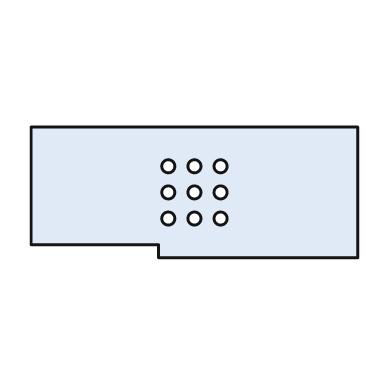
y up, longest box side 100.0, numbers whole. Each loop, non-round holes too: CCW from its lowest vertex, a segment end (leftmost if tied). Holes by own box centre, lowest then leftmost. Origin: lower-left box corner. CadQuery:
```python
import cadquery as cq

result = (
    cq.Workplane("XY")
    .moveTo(39.0, 0.0)
    .lineTo(100.0, 0.0)
    .lineTo(100.0, 40.0)
    .lineTo(0.0, 40.0)
    .lineTo(0.0, 4.0)
    .lineTo(39.0, 4.0)
    .close()
    .moveTo(42.0, 12.0)
    .circle(2.0)
    .moveTo(50.0, 12.0)
    .circle(2.0)
    .moveTo(58.0, 12.0)
    .circle(2.0)
    .moveTo(42.0, 20.0)
    .circle(2.0)
    .moveTo(50.0, 20.0)
    .circle(2.0)
    .moveTo(58.0, 20.0)
    .circle(2.0)
    .moveTo(42.0, 28.0)
    .circle(2.0)
    .moveTo(50.0, 28.0)
    .circle(2.0)
    .moveTo(58.0, 28.0)
    .circle(2.0)
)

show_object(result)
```